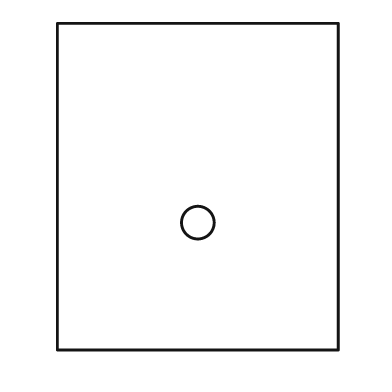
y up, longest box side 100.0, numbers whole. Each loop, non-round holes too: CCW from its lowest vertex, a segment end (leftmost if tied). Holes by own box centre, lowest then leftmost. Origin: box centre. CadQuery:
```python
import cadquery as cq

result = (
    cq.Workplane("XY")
    .moveTo(-43.0, -50.0)
    .lineTo(43.0, -50.0)
    .lineTo(43.0, 50.0)
    .lineTo(-43.0, 50.0)
    .close()
    .moveTo(0.0, -11.0)
    .circle(5.0)
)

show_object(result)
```